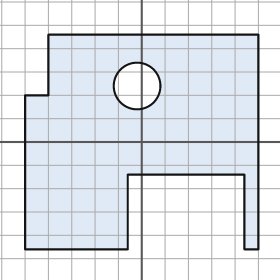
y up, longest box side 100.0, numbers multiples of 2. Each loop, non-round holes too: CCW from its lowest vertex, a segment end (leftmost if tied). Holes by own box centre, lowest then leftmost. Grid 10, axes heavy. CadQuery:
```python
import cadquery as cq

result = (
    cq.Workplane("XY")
    .moveTo(-50.0, -46.0)
    .lineTo(-6.0, -46.0)
    .lineTo(-6.0, -14.0)
    .lineTo(44.0, -14.0)
    .lineTo(44.0, -46.0)
    .lineTo(50.0, -46.0)
    .lineTo(50.0, 46.0)
    .lineTo(-40.0, 46.0)
    .lineTo(-40.0, 20.0)
    .lineTo(-50.0, 20.0)
    .close()
    .moveTo(-2.0, 24.0)
    .circle(10.0)
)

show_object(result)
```